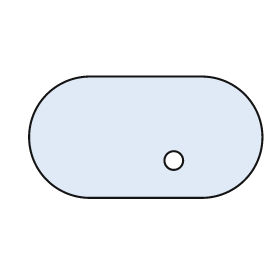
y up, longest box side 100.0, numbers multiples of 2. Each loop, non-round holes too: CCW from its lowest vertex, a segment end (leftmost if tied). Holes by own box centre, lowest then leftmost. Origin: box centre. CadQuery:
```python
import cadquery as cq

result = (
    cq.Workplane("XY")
    .moveTo(-24.0, -26.0)
    .lineTo(24.0, -26.0)
    .threePointArc((50.0, 0.0), (24.0, 26.0))
    .lineTo(-24.0, 26.0)
    .threePointArc((-50.0, 0.0), (-24.0, -26.0))
    .close()
    .moveTo(12.0, -10.0)
    .circle(4.0)
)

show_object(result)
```